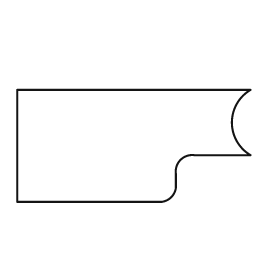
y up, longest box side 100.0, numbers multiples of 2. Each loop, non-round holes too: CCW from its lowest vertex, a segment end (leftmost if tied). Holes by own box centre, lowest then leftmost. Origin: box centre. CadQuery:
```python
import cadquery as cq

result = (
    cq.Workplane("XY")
    .moveTo(-50.0, -24.0)
    .lineTo(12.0, -24.0)
    .threePointArc((16.0, -22.0), (18.0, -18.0))
    .lineTo(18.0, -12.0)
    .threePointArc((20.0, -6.0), (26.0, -4.0))
    .lineTo(50.0, -4.0)
    .threePointArc((42.0, 10.0), (50.0, 24.0))
    .lineTo(-50.0, 24.0)
    .close()
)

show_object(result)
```